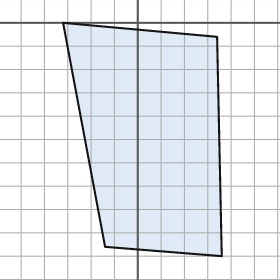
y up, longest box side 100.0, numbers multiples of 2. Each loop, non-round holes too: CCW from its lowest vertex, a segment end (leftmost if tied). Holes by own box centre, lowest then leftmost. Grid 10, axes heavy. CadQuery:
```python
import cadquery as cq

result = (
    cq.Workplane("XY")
    .moveTo(36.0, -100.0)
    .lineTo(34.0, -6.0)
    .lineTo(-32.0, 0.0)
    .lineTo(-14.0, -96.0)
    .close()
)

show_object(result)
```